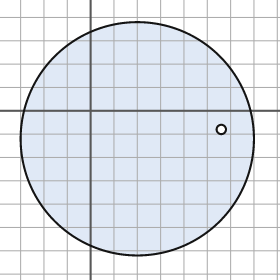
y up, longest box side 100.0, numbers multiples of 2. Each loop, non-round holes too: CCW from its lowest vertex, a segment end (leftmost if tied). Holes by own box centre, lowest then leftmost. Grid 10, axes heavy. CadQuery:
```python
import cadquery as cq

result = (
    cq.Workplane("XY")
    .moveTo(20.0, -12.0)
    .circle(50.0)
    .moveTo(56.0, -8.0)
    .circle(2.0)
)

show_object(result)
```